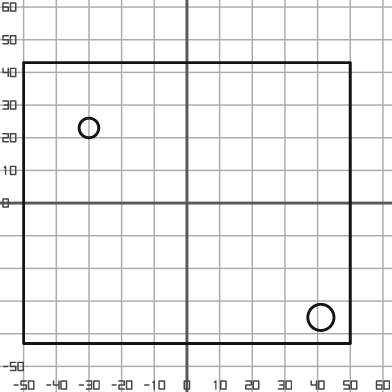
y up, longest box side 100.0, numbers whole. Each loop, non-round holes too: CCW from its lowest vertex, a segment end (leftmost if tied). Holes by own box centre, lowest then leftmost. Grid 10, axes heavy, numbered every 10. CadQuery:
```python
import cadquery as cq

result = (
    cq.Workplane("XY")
    .moveTo(-50.0, -43.0)
    .lineTo(50.0, -43.0)
    .lineTo(50.0, 43.0)
    .lineTo(-50.0, 43.0)
    .close()
    .moveTo(41.0, -35.0)
    .circle(4.0)
    .moveTo(-30.0, 23.0)
    .circle(3.0)
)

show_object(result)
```